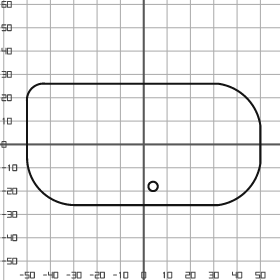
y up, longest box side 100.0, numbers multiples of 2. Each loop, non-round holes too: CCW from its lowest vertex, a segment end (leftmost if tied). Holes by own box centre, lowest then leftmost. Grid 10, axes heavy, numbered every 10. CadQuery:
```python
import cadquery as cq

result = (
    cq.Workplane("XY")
    .moveTo(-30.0, -26.0)
    .lineTo(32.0, -26.0)
    .threePointArc((44.0, -20.0), (50.0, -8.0))
    .lineTo(50.0, 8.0)
    .threePointArc((44.0, 20.0), (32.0, 26.0))
    .lineTo(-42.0, 26.0)
    .threePointArc((-48.0, 24.0), (-50.0, 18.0))
    .lineTo(-50.0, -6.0)
    .threePointArc((-44.0, -20.0), (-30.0, -26.0))
    .close()
    .moveTo(4.0, -18.0)
    .circle(2.0)
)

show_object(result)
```